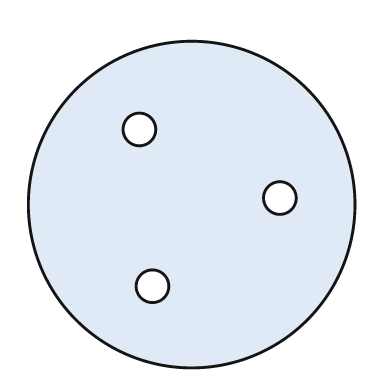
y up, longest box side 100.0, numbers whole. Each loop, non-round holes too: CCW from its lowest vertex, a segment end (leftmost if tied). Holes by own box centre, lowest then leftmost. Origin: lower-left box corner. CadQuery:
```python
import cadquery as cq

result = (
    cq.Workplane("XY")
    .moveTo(50.0, 50.0)
    .circle(50.0)
    .moveTo(38.0, 25.0)
    .circle(5.0)
    .moveTo(77.0, 52.0)
    .circle(5.0)
    .moveTo(34.0, 73.0)
    .circle(5.0)
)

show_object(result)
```